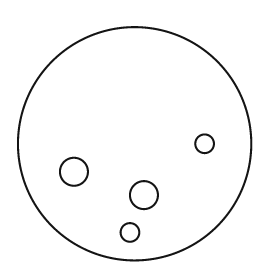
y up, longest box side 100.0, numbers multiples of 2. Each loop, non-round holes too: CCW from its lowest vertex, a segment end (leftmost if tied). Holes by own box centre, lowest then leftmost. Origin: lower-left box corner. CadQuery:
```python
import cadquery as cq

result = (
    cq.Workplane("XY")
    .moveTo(50.0, 50.0)
    .circle(50.0)
    .moveTo(48.0, 12.0)
    .circle(4.0)
    .moveTo(54.0, 28.0)
    .circle(6.0)
    .moveTo(24.0, 38.0)
    .circle(6.0)
    .moveTo(80.0, 50.0)
    .circle(4.0)
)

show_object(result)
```